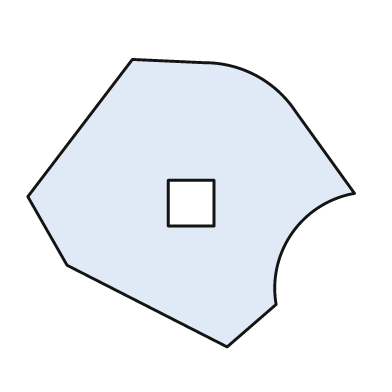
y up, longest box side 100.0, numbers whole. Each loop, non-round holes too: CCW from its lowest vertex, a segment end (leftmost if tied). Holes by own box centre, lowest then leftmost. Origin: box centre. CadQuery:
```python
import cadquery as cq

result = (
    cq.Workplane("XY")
    .moveTo(11.0, -44.0)
    .lineTo(26.0, -31.0)
    .threePointArc((31.0, -9.0), (50.0, 3.0))
    .lineTo(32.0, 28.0)
    .threePointArc((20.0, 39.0), (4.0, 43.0))
    .lineTo(-18.0, 44.0)
    .lineTo(-50.0, 2.0)
    .lineTo(-38.0, -19.0)
    .close()
    .moveTo(-7.0, -7.0)
    .lineTo(7.0, -7.0)
    .lineTo(7.0, 7.0)
    .lineTo(-7.0, 7.0)
    .close()
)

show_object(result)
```